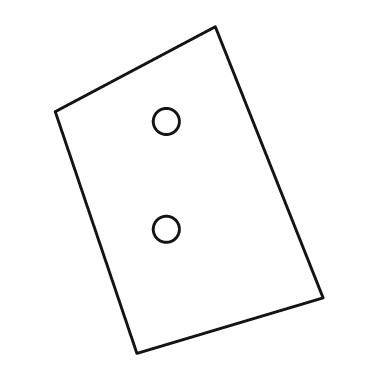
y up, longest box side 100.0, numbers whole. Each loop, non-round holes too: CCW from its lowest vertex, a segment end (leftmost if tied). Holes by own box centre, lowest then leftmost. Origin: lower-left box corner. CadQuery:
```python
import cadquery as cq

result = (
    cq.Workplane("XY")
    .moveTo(25.0, 0.0)
    .lineTo(82.0, 17.0)
    .lineTo(49.0, 100.0)
    .lineTo(0.0, 74.0)
    .close()
    .moveTo(34.0, 38.0)
    .circle(4.0)
    .moveTo(34.0, 71.0)
    .circle(4.0)
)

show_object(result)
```